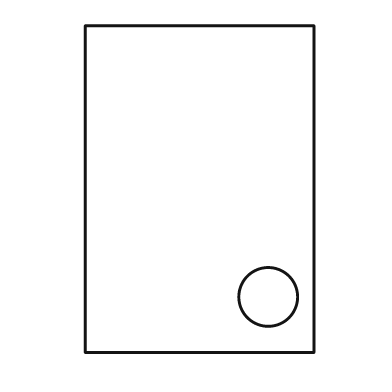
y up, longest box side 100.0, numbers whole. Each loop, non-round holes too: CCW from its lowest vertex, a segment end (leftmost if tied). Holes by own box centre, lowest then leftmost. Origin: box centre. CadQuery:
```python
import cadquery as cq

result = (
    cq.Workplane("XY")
    .moveTo(-35.0, -50.0)
    .lineTo(35.0, -50.0)
    .lineTo(35.0, 50.0)
    .lineTo(-35.0, 50.0)
    .close()
    .moveTo(21.0, -33.0)
    .circle(9.0)
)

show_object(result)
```